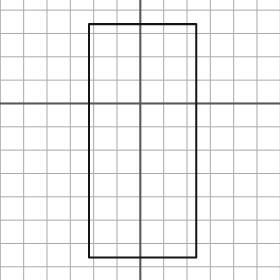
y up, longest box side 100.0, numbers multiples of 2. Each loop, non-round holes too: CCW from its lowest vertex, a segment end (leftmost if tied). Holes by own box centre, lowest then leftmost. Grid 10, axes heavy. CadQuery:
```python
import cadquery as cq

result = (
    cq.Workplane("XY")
    .moveTo(-22.0, -66.0)
    .lineTo(24.0, -66.0)
    .lineTo(24.0, 34.0)
    .lineTo(-22.0, 34.0)
    .close()
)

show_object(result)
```